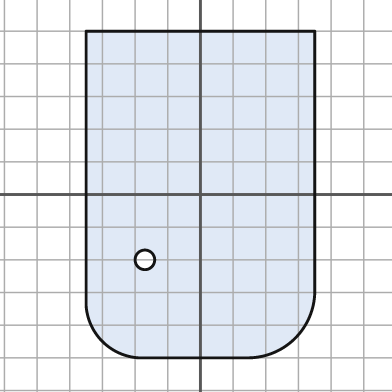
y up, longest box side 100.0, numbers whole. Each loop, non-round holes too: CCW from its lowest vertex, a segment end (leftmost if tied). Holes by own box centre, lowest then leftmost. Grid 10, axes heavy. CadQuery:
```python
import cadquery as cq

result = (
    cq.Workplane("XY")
    .moveTo(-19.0, -50.0)
    .lineTo(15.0, -50.0)
    .threePointArc((29.0, -44.0), (35.0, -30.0))
    .lineTo(35.0, 50.0)
    .lineTo(-35.0, 50.0)
    .lineTo(-35.0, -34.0)
    .threePointArc((-30.0, -45.0), (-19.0, -50.0))
    .close()
    .moveTo(-17.0, -20.0)
    .circle(3.0)
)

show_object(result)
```